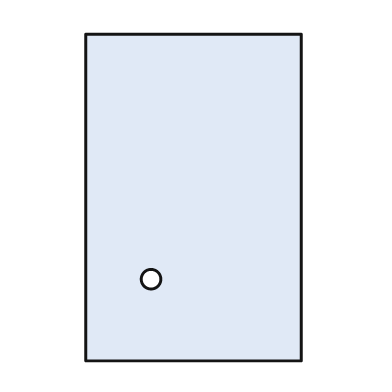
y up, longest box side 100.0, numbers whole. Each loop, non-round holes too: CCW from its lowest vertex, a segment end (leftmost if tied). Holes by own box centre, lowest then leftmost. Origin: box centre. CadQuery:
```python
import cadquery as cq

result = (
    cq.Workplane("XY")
    .moveTo(-33.0, -50.0)
    .lineTo(33.0, -50.0)
    .lineTo(33.0, 50.0)
    .lineTo(-33.0, 50.0)
    .close()
    .moveTo(-13.0, -25.0)
    .circle(3.0)
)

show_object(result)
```